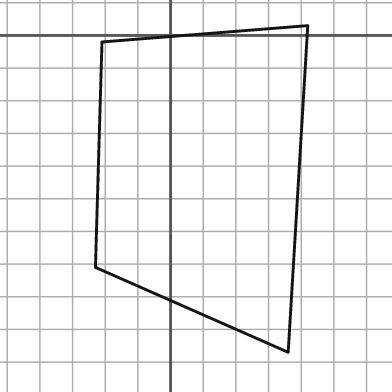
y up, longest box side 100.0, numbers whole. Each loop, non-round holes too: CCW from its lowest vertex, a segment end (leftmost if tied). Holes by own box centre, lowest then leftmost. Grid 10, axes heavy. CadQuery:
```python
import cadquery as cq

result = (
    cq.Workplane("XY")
    .moveTo(36.0, -97.0)
    .lineTo(42.0, 3.0)
    .lineTo(-21.0, -2.0)
    .lineTo(-23.0, -71.0)
    .close()
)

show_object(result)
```